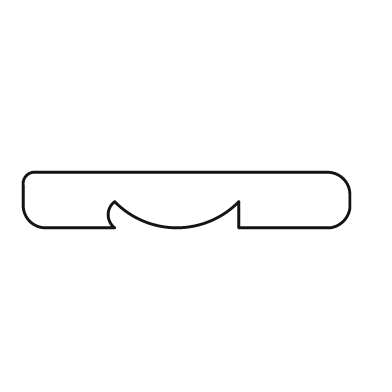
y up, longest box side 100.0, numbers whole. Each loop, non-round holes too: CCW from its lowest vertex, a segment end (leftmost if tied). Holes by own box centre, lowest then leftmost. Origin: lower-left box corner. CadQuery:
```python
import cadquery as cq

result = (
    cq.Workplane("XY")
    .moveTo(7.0, 0.0)
    .lineTo(28.0, 0.0)
    .threePointArc((26.0, 4.0), (28.0, 8.0))
    .threePointArc((47.0, 0.0), (66.0, 8.0))
    .lineTo(66.0, 0.0)
    .lineTo(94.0, 0.0)
    .threePointArc((98.0, 2.0), (100.0, 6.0))
    .lineTo(100.0, 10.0)
    .threePointArc((98.0, 15.0), (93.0, 17.0))
    .lineTo(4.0, 17.0)
    .threePointArc((1.0, 16.0), (0.0, 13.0))
    .lineTo(0.0, 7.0)
    .threePointArc((2.0, 2.0), (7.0, 0.0))
    .close()
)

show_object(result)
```